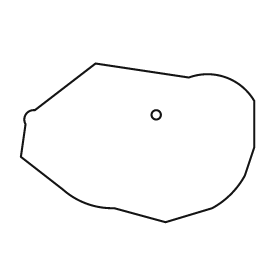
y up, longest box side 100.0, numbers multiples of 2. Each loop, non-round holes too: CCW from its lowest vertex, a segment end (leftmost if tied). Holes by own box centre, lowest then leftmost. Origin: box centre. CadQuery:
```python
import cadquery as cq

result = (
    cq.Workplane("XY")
    .moveTo(12.0, -34.0)
    .lineTo(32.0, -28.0)
    .threePointArc((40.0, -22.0), (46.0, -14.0))
    .lineTo(50.0, -2.0)
    .lineTo(50.0, 18.0)
    .threePointArc((38.0, 28.0), (22.0, 28.0))
    .lineTo(-18.0, 34.0)
    .lineTo(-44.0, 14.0)
    .threePointArc((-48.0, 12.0), (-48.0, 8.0))
    .lineTo(-50.0, -6.0)
    .lineTo(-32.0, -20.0)
    .threePointArc((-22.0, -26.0), (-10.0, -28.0))
    .close()
    .moveTo(8.0, 12.0)
    .circle(2.0)
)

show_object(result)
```